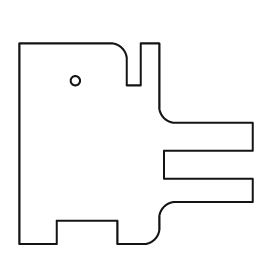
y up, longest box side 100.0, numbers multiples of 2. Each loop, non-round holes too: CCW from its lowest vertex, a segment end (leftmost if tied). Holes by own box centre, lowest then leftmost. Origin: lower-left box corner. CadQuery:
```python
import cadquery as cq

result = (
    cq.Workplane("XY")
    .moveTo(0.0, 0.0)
    .lineTo(16.0, 0.0)
    .lineTo(16.0, 10.0)
    .lineTo(42.0, 10.0)
    .lineTo(42.0, 0.0)
    .lineTo(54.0, 0.0)
    .threePointArc((58.0, 2.0), (60.0, 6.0))
    .lineTo(60.0, 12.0)
    .threePointArc((62.0, 16.0), (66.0, 18.0))
    .lineTo(100.0, 18.0)
    .lineTo(100.0, 28.0)
    .lineTo(62.0, 28.0)
    .lineTo(62.0, 40.0)
    .lineTo(100.0, 40.0)
    .lineTo(100.0, 52.0)
    .lineTo(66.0, 52.0)
    .threePointArc((62.0, 54.0), (60.0, 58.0))
    .lineTo(60.0, 86.0)
    .lineTo(52.0, 86.0)
    .lineTo(52.0, 68.0)
    .lineTo(46.0, 68.0)
    .lineTo(46.0, 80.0)
    .threePointArc((44.0, 84.0), (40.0, 86.0))
    .lineTo(0.0, 86.0)
    .close()
    .moveTo(24.0, 70.0)
    .circle(2.0)
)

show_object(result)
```